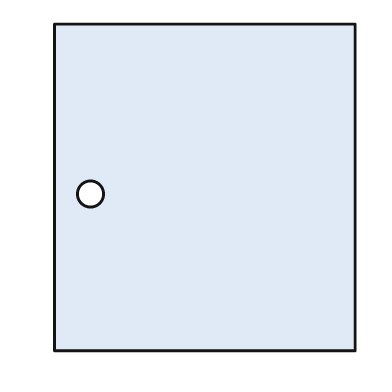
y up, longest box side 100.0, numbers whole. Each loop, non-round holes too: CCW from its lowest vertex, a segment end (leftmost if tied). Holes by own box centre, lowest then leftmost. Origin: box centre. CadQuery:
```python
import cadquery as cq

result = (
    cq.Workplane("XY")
    .moveTo(-46.0, -50.0)
    .lineTo(46.0, -50.0)
    .lineTo(46.0, 50.0)
    .lineTo(-46.0, 50.0)
    .close()
    .moveTo(-35.0, -2.0)
    .circle(4.0)
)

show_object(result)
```